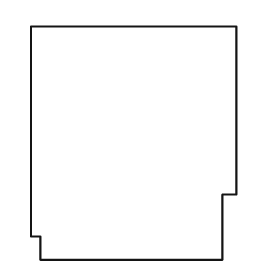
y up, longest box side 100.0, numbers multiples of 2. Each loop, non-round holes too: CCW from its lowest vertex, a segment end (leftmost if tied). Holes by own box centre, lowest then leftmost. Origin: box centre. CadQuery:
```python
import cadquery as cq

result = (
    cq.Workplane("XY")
    .moveTo(-40.0, -50.0)
    .lineTo(38.0, -50.0)
    .lineTo(38.0, -22.0)
    .lineTo(44.0, -22.0)
    .lineTo(44.0, 50.0)
    .lineTo(-44.0, 50.0)
    .lineTo(-44.0, -40.0)
    .lineTo(-40.0, -40.0)
    .close()
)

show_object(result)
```